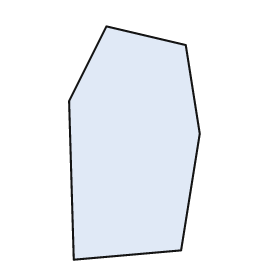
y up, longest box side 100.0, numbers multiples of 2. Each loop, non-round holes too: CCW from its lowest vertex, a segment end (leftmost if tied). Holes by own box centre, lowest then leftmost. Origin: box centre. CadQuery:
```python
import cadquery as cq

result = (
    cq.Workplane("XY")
    .moveTo(-26.0, -50.0)
    .lineTo(20.0, -46.0)
    .lineTo(28.0, 4.0)
    .lineTo(22.0, 42.0)
    .lineTo(-12.0, 50.0)
    .lineTo(-28.0, 18.0)
    .close()
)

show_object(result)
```